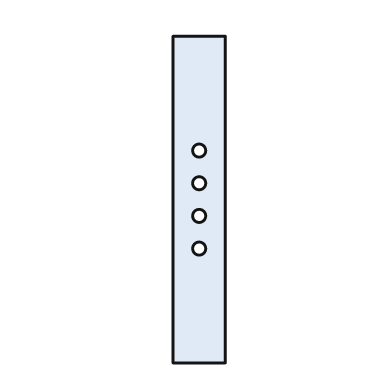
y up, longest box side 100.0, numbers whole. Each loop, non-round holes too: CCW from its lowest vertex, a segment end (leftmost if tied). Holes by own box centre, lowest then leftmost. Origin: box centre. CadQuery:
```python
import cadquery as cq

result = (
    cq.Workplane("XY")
    .moveTo(-8.0, -50.0)
    .lineTo(8.0, -50.0)
    .lineTo(8.0, 50.0)
    .lineTo(-8.0, 50.0)
    .close()
    .moveTo(0.0, -15.0)
    .circle(2.0)
    .moveTo(0.0, -5.0)
    .circle(2.0)
    .moveTo(0.0, 5.0)
    .circle(2.0)
    .moveTo(0.0, 15.0)
    .circle(2.0)
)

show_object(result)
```